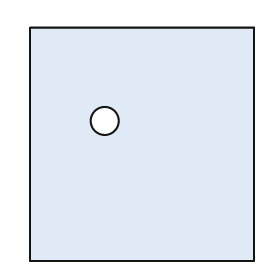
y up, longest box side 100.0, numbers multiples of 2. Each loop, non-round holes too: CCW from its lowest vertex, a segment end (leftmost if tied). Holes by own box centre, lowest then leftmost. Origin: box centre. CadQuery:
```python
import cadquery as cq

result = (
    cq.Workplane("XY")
    .moveTo(-48.0, -50.0)
    .lineTo(48.0, -50.0)
    .lineTo(48.0, 50.0)
    .lineTo(-48.0, 50.0)
    .close()
    .moveTo(-16.0, 10.0)
    .circle(6.0)
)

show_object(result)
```